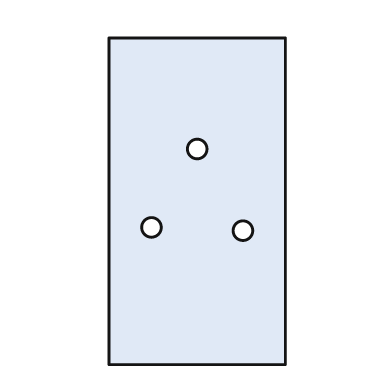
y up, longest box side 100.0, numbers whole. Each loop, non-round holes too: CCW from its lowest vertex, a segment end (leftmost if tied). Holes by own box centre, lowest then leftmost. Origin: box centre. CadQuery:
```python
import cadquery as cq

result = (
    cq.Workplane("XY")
    .moveTo(-27.0, -50.0)
    .lineTo(27.0, -50.0)
    .lineTo(27.0, 50.0)
    .lineTo(-27.0, 50.0)
    .close()
    .moveTo(14.0, -9.0)
    .circle(3.0)
    .moveTo(-14.0, -8.0)
    .circle(3.0)
    .moveTo(0.0, 16.0)
    .circle(3.0)
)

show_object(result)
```